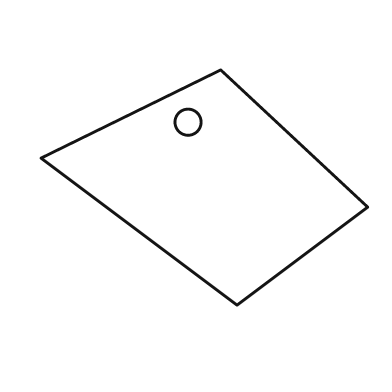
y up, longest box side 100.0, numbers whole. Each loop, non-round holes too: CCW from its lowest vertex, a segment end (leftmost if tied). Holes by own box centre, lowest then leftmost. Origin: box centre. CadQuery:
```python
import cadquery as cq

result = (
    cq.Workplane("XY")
    .moveTo(10.0, -36.0)
    .lineTo(50.0, -6.0)
    .lineTo(5.0, 36.0)
    .lineTo(-50.0, 9.0)
    .close()
    .moveTo(-5.0, 20.0)
    .circle(4.0)
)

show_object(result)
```